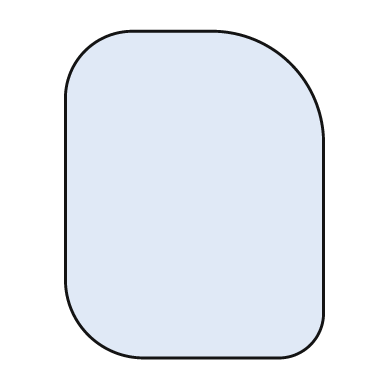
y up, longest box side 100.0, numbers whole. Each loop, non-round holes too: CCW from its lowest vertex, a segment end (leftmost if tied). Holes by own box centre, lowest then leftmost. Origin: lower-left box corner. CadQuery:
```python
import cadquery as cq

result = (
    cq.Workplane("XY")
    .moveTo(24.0, 0.0)
    .lineTo(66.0, 0.0)
    .threePointArc((75.0, 4.0), (79.0, 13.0))
    .lineTo(79.0, 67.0)
    .threePointArc((69.0, 90.0), (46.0, 100.0))
    .lineTo(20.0, 100.0)
    .threePointArc((6.0, 94.0), (0.0, 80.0))
    .lineTo(0.0, 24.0)
    .threePointArc((7.0, 7.0), (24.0, 0.0))
    .close()
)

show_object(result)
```